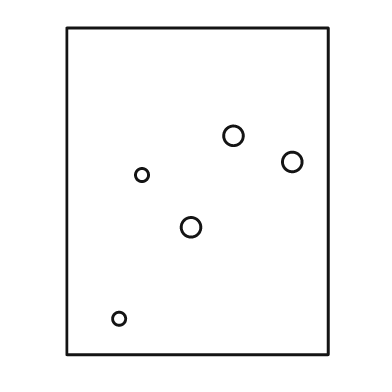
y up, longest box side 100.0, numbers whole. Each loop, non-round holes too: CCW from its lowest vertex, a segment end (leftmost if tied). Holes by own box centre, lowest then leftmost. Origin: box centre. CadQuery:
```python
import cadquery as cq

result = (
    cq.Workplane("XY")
    .moveTo(-40.0, -50.0)
    .lineTo(40.0, -50.0)
    .lineTo(40.0, 50.0)
    .lineTo(-40.0, 50.0)
    .close()
    .moveTo(-24.0, -39.0)
    .circle(2.0)
    .moveTo(-2.0, -11.0)
    .circle(3.0)
    .moveTo(-17.0, 5.0)
    .circle(2.0)
    .moveTo(29.0, 9.0)
    .circle(3.0)
    .moveTo(11.0, 17.0)
    .circle(3.0)
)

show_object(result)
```